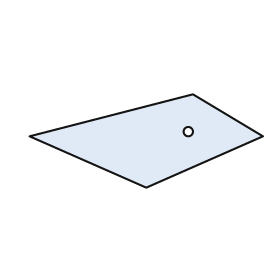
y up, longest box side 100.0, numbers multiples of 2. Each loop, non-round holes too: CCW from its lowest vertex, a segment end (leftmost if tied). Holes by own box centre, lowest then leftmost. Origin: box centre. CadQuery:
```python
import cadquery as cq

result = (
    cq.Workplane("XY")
    .moveTo(0.0, -20.0)
    .lineTo(50.0, 2.0)
    .lineTo(20.0, 20.0)
    .lineTo(-50.0, 2.0)
    .close()
    .moveTo(18.0, 4.0)
    .circle(2.0)
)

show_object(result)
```